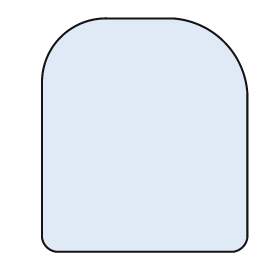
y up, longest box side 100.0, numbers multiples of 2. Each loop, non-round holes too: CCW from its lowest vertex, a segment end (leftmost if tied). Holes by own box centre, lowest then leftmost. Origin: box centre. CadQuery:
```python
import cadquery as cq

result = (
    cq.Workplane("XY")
    .moveTo(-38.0, -50.0)
    .lineTo(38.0, -50.0)
    .threePointArc((42.0, -48.0), (44.0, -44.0))
    .lineTo(44.0, 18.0)
    .threePointArc((34.0, 40.0), (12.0, 50.0))
    .lineTo(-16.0, 50.0)
    .threePointArc((-36.0, 42.0), (-44.0, 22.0))
    .lineTo(-44.0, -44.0)
    .threePointArc((-42.0, -48.0), (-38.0, -50.0))
    .close()
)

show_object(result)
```